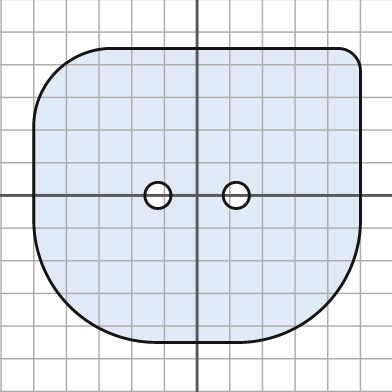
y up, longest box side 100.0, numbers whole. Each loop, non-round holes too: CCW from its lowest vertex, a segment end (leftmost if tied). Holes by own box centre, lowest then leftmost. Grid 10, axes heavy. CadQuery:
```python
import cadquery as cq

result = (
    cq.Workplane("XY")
    .moveTo(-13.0, -45.0)
    .lineTo(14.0, -45.0)
    .threePointArc((39.0, -34.0), (50.0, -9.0))
    .lineTo(50.0, 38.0)
    .threePointArc((48.0, 43.0), (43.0, 45.0))
    .lineTo(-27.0, 45.0)
    .threePointArc((-43.0, 38.0), (-50.0, 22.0))
    .lineTo(-50.0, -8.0)
    .threePointArc((-39.0, -34.0), (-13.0, -45.0))
    .close()
    .moveTo(-12.0, 0.0)
    .circle(4.0)
    .moveTo(12.0, 0.0)
    .circle(4.0)
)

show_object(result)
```